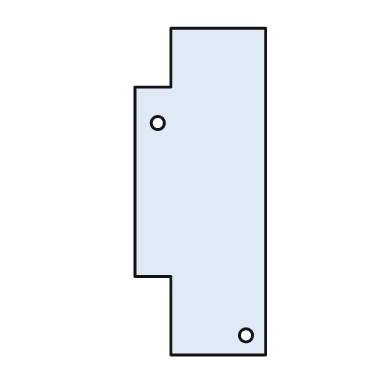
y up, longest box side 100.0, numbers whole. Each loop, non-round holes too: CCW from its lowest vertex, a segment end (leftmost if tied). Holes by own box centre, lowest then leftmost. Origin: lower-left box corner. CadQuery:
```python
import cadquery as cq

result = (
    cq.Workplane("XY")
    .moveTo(11.0, 0.0)
    .lineTo(40.0, 0.0)
    .lineTo(40.0, 100.0)
    .lineTo(11.0, 100.0)
    .lineTo(11.0, 82.0)
    .lineTo(0.0, 82.0)
    .lineTo(0.0, 24.0)
    .lineTo(11.0, 24.0)
    .close()
    .moveTo(34.0, 6.0)
    .circle(2.0)
    .moveTo(7.0, 71.0)
    .circle(2.0)
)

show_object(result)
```